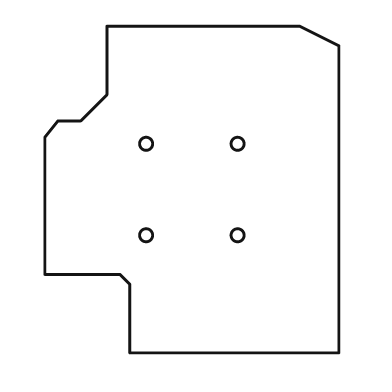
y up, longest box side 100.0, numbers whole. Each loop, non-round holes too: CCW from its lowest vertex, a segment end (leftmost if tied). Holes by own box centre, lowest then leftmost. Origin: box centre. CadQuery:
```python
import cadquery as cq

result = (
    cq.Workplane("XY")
    .moveTo(-19.0, -50.0)
    .lineTo(45.0, -50.0)
    .lineTo(45.0, 44.0)
    .lineTo(33.0, 50.0)
    .lineTo(-26.0, 50.0)
    .lineTo(-26.0, 29.0)
    .lineTo(-34.0, 21.0)
    .lineTo(-41.0, 21.0)
    .lineTo(-45.0, 16.0)
    .lineTo(-45.0, -26.0)
    .lineTo(-22.0, -26.0)
    .lineTo(-19.0, -29.0)
    .close()
    .moveTo(-14.0, -14.0)
    .circle(2.0)
    .moveTo(14.0, -14.0)
    .circle(2.0)
    .moveTo(-14.0, 14.0)
    .circle(2.0)
    .moveTo(14.0, 14.0)
    .circle(2.0)
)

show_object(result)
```